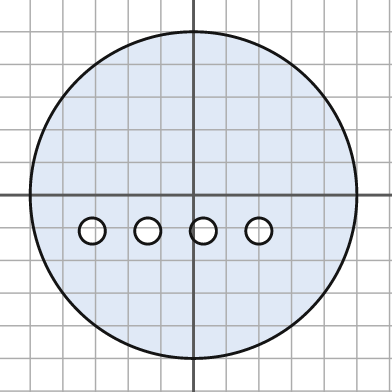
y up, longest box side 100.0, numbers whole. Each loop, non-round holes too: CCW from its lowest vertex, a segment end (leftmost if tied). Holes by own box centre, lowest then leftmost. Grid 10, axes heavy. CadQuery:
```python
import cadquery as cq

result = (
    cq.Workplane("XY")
    .moveTo(0.0, 0.0)
    .circle(50.0)
    .moveTo(-31.0, -11.0)
    .circle(4.0)
    .moveTo(-14.0, -11.0)
    .circle(4.0)
    .moveTo(3.0, -11.0)
    .circle(4.0)
    .moveTo(20.0, -11.0)
    .circle(4.0)
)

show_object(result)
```